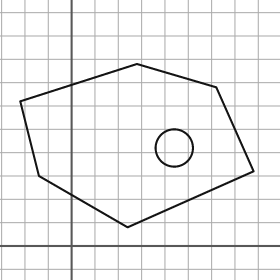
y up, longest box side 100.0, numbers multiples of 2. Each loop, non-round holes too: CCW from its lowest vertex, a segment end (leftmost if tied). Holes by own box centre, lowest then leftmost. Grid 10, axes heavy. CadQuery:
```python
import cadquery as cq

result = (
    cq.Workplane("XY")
    .moveTo(24.0, 8.0)
    .lineTo(78.0, 32.0)
    .lineTo(62.0, 68.0)
    .lineTo(28.0, 78.0)
    .lineTo(-22.0, 62.0)
    .lineTo(-14.0, 30.0)
    .close()
    .moveTo(44.0, 42.0)
    .circle(8.0)
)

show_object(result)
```